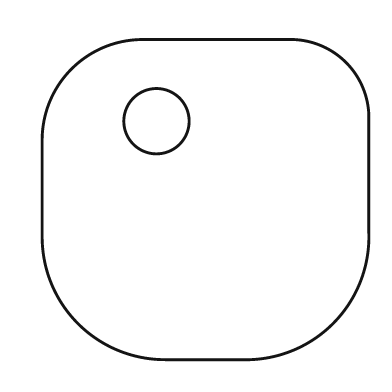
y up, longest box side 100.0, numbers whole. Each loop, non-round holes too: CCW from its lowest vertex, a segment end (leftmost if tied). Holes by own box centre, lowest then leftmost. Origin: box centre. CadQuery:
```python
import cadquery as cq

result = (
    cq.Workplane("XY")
    .moveTo(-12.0, -49.0)
    .lineTo(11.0, -49.0)
    .threePointArc((39.0, -38.0), (50.0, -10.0))
    .lineTo(50.0, 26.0)
    .threePointArc((43.0, 42.0), (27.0, 49.0))
    .lineTo(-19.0, 49.0)
    .threePointArc((-41.0, 40.0), (-50.0, 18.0))
    .lineTo(-50.0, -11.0)
    .threePointArc((-39.0, -38.0), (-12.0, -49.0))
    .close()
    .moveTo(-15.0, 24.0)
    .circle(10.0)
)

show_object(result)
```